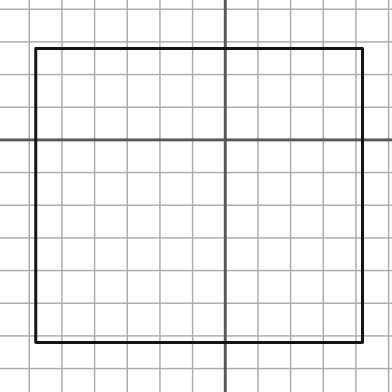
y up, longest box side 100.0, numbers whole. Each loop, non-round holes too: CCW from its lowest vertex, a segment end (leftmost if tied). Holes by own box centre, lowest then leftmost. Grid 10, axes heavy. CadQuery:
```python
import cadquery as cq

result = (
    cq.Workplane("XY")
    .moveTo(-58.0, -62.0)
    .lineTo(42.0, -62.0)
    .lineTo(42.0, 28.0)
    .lineTo(-58.0, 28.0)
    .close()
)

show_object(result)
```